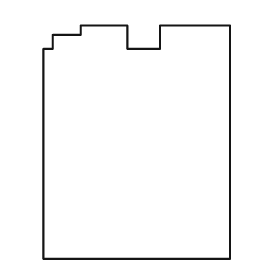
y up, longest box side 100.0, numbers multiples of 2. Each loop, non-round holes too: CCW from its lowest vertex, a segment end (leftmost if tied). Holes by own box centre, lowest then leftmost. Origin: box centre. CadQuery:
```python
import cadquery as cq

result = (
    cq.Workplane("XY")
    .moveTo(-40.0, -50.0)
    .lineTo(40.0, -50.0)
    .lineTo(40.0, 50.0)
    .lineTo(10.0, 50.0)
    .lineTo(10.0, 40.0)
    .lineTo(-4.0, 40.0)
    .lineTo(-4.0, 50.0)
    .lineTo(-24.0, 50.0)
    .lineTo(-24.0, 46.0)
    .lineTo(-36.0, 46.0)
    .lineTo(-36.0, 40.0)
    .lineTo(-40.0, 40.0)
    .close()
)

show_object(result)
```